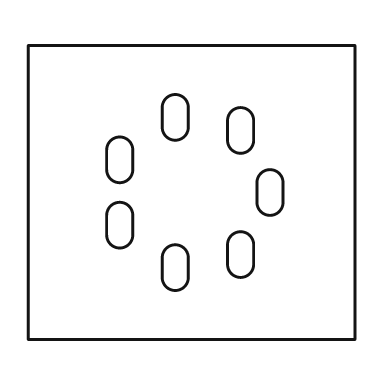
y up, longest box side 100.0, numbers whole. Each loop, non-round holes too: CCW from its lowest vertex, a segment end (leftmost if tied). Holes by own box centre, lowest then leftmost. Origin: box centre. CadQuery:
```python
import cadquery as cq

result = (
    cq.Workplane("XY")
    .moveTo(-50.0, -45.0)
    .lineTo(50.0, -45.0)
    .lineTo(50.0, 45.0)
    .lineTo(-50.0, 45.0)
    .close()
    .moveTo(-9.0, -26.0)
    .threePointArc((-5.0, -30.0), (-1.0, -26.0))
    .lineTo(-1.0, -20.0)
    .threePointArc((-5.0, -16.0), (-9.0, -20.0))
    .close()
    .moveTo(11.0, -22.0)
    .threePointArc((15.0, -26.0), (19.0, -22.0))
    .lineTo(19.0, -16.0)
    .threePointArc((15.0, -12.0), (11.0, -16.0))
    .close()
    .moveTo(-26.0, -13.0)
    .threePointArc((-22.0, -17.0), (-18.0, -13.0))
    .lineTo(-18.0, -7.0)
    .threePointArc((-22.0, -3.0), (-26.0, -7.0))
    .close()
    .moveTo(20.0, -3.0)
    .threePointArc((24.0, -7.0), (28.0, -3.0))
    .lineTo(28.0, 3.0)
    .threePointArc((24.0, 7.0), (20.0, 3.0))
    .close()
    .moveTo(-26.0, 7.0)
    .threePointArc((-22.0, 3.0), (-18.0, 7.0))
    .lineTo(-18.0, 13.0)
    .threePointArc((-22.0, 17.0), (-26.0, 13.0))
    .close()
    .moveTo(11.0, 16.0)
    .threePointArc((15.0, 12.0), (19.0, 16.0))
    .lineTo(19.0, 22.0)
    .threePointArc((15.0, 26.0), (11.0, 22.0))
    .close()
    .moveTo(-9.0, 20.0)
    .threePointArc((-5.0, 16.0), (-1.0, 20.0))
    .lineTo(-1.0, 26.0)
    .threePointArc((-5.0, 30.0), (-9.0, 26.0))
    .close()
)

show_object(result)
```